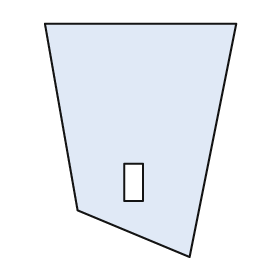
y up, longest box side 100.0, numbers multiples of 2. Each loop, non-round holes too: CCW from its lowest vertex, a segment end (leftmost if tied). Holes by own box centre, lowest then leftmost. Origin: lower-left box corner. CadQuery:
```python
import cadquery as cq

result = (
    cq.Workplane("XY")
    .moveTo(62.0, 0.0)
    .lineTo(82.0, 100.0)
    .lineTo(0.0, 100.0)
    .lineTo(14.0, 20.0)
    .close()
    .moveTo(34.0, 24.0)
    .lineTo(42.0, 24.0)
    .lineTo(42.0, 40.0)
    .lineTo(34.0, 40.0)
    .close()
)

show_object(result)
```